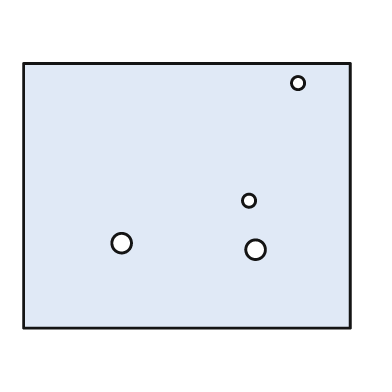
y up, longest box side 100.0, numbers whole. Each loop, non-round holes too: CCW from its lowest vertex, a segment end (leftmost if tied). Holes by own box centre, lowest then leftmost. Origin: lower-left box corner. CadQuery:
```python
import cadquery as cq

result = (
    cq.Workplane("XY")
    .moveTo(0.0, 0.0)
    .lineTo(100.0, 0.0)
    .lineTo(100.0, 81.0)
    .lineTo(0.0, 81.0)
    .close()
    .moveTo(71.0, 24.0)
    .circle(3.0)
    .moveTo(30.0, 26.0)
    .circle(3.0)
    .moveTo(69.0, 39.0)
    .circle(2.0)
    .moveTo(84.0, 75.0)
    .circle(2.0)
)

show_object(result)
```